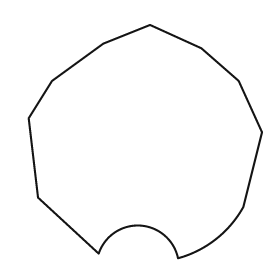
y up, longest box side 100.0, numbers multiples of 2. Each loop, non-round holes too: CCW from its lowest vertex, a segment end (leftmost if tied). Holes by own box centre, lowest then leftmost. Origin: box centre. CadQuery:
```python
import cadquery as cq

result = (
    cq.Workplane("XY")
    .moveTo(14.0, -50.0)
    .threePointArc((30.0, -42.0), (42.0, -28.0))
    .lineTo(50.0, 4.0)
    .lineTo(40.0, 26.0)
    .lineTo(24.0, 40.0)
    .lineTo(2.0, 50.0)
    .lineTo(-18.0, 42.0)
    .lineTo(-40.0, 26.0)
    .lineTo(-50.0, 10.0)
    .lineTo(-46.0, -24.0)
    .lineTo(-20.0, -48.0)
    .threePointArc((-2.0, -36.0), (14.0, -50.0))
    .close()
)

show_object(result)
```